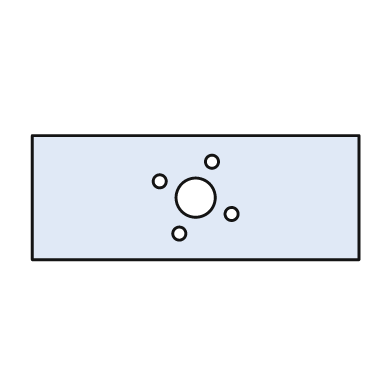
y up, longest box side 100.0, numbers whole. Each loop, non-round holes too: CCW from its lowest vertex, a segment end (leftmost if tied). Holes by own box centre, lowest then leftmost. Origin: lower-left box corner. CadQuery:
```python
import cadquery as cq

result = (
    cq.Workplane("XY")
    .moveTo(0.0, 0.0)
    .lineTo(100.0, 0.0)
    .lineTo(100.0, 38.0)
    .lineTo(0.0, 38.0)
    .close()
    .moveTo(45.0, 8.0)
    .circle(2.0)
    .moveTo(61.0, 14.0)
    .circle(2.0)
    .moveTo(50.0, 19.0)
    .circle(6.0)
    .moveTo(39.0, 24.0)
    .circle(2.0)
    .moveTo(55.0, 30.0)
    .circle(2.0)
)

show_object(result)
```